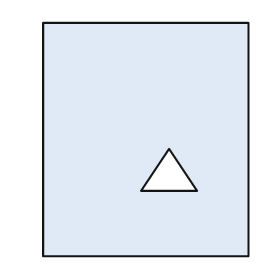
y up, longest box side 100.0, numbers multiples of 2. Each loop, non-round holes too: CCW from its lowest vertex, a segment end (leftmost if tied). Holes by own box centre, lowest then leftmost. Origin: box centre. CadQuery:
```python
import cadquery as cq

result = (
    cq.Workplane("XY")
    .moveTo(-44.0, -50.0)
    .lineTo(44.0, -50.0)
    .lineTo(44.0, 50.0)
    .lineTo(-44.0, 50.0)
    .close()
    .moveTo(-2.0, -22.0)
    .lineTo(22.0, -22.0)
    .lineTo(10.0, -4.0)
    .close()
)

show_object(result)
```